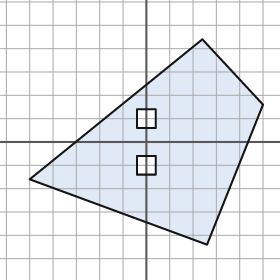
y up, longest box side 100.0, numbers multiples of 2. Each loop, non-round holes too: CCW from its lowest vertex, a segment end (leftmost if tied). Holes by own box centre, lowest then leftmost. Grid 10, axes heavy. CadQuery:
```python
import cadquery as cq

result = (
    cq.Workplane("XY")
    .moveTo(26.0, -44.0)
    .lineTo(50.0, 16.0)
    .lineTo(24.0, 44.0)
    .lineTo(-50.0, -16.0)
    .close()
    .moveTo(-4.0, -14.0)
    .lineTo(4.0, -14.0)
    .lineTo(4.0, -6.0)
    .lineTo(-4.0, -6.0)
    .close()
    .moveTo(-4.0, 6.0)
    .lineTo(4.0, 6.0)
    .lineTo(4.0, 14.0)
    .lineTo(-4.0, 14.0)
    .close()
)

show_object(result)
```